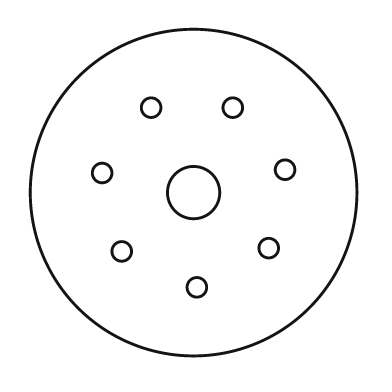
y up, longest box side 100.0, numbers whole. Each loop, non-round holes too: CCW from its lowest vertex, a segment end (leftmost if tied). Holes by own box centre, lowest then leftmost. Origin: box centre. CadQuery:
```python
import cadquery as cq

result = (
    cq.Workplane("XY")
    .moveTo(0.0, 0.0)
    .circle(50.0)
    .moveTo(1.0, -29.0)
    .circle(3.0)
    .moveTo(-22.0, -18.0)
    .circle(3.0)
    .moveTo(23.0, -17.0)
    .circle(3.0)
    .moveTo(0.0, 0.0)
    .circle(8.0)
    .moveTo(-28.0, 6.0)
    .circle(3.0)
    .moveTo(28.0, 7.0)
    .circle(3.0)
    .moveTo(-13.0, 26.0)
    .circle(3.0)
    .moveTo(12.0, 26.0)
    .circle(3.0)
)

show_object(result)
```